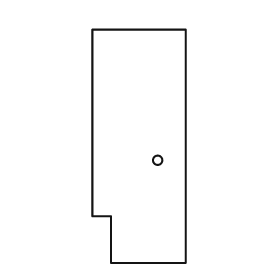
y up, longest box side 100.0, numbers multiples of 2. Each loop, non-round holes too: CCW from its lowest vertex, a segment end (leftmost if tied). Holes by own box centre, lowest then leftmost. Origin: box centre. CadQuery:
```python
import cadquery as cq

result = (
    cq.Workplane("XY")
    .moveTo(-12.0, -50.0)
    .lineTo(20.0, -50.0)
    .lineTo(20.0, 50.0)
    .lineTo(-20.0, 50.0)
    .lineTo(-20.0, -30.0)
    .lineTo(-12.0, -30.0)
    .close()
    .moveTo(8.0, -6.0)
    .circle(2.0)
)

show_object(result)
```